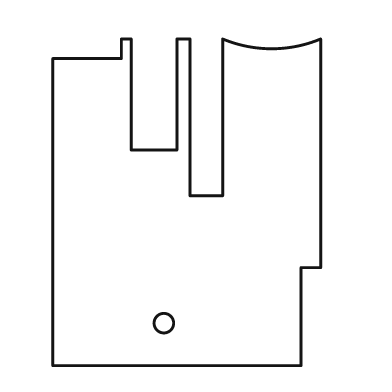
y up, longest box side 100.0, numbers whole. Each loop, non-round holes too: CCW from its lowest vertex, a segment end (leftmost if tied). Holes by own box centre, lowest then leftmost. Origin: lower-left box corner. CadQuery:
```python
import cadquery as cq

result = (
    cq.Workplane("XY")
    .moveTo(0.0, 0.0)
    .lineTo(76.0, 0.0)
    .lineTo(76.0, 30.0)
    .lineTo(82.0, 30.0)
    .lineTo(82.0, 100.0)
    .threePointArc((67.0, 97.0), (52.0, 100.0))
    .lineTo(52.0, 52.0)
    .lineTo(42.0, 52.0)
    .lineTo(42.0, 100.0)
    .lineTo(38.0, 100.0)
    .lineTo(38.0, 66.0)
    .lineTo(24.0, 66.0)
    .lineTo(24.0, 100.0)
    .lineTo(21.0, 100.0)
    .lineTo(21.0, 94.0)
    .lineTo(0.0, 94.0)
    .close()
    .moveTo(34.0, 13.0)
    .circle(3.0)
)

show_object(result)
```